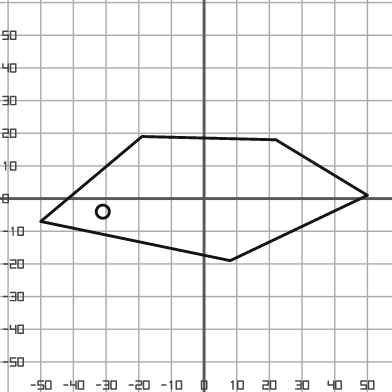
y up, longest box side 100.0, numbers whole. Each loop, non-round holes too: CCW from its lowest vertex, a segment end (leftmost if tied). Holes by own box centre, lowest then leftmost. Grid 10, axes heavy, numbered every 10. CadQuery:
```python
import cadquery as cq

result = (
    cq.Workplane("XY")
    .moveTo(8.0, -19.0)
    .lineTo(50.0, 1.0)
    .lineTo(22.0, 18.0)
    .lineTo(-19.0, 19.0)
    .lineTo(-50.0, -7.0)
    .close()
    .moveTo(-31.0, -4.0)
    .circle(2.0)
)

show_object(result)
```